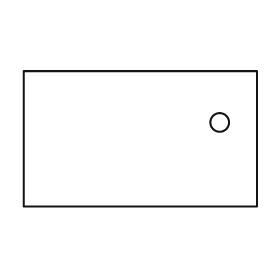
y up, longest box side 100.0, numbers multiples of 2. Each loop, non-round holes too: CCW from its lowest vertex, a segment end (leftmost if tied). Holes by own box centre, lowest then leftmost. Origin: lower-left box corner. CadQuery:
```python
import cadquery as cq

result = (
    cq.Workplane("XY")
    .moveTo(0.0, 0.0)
    .lineTo(100.0, 0.0)
    .lineTo(100.0, 58.0)
    .lineTo(0.0, 58.0)
    .close()
    .moveTo(84.0, 36.0)
    .circle(4.0)
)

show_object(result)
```